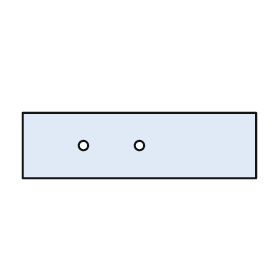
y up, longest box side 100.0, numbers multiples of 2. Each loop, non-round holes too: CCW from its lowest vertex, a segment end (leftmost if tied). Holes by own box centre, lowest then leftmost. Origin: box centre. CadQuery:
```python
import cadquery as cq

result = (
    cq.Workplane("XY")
    .moveTo(-50.0, -14.0)
    .lineTo(50.0, -14.0)
    .lineTo(50.0, 14.0)
    .lineTo(-50.0, 14.0)
    .close()
    .moveTo(-24.0, 0.0)
    .circle(2.0)
    .moveTo(0.0, 0.0)
    .circle(2.0)
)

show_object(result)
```